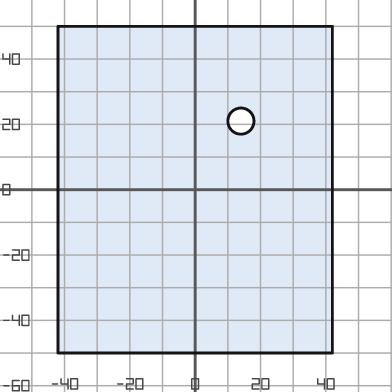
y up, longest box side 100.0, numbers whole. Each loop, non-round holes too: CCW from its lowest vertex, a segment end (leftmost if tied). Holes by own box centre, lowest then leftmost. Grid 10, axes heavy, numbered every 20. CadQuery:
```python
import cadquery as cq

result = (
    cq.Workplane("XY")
    .moveTo(-42.0, -50.0)
    .lineTo(42.0, -50.0)
    .lineTo(42.0, 50.0)
    .lineTo(-42.0, 50.0)
    .close()
    .moveTo(14.0, 21.0)
    .circle(4.0)
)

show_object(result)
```